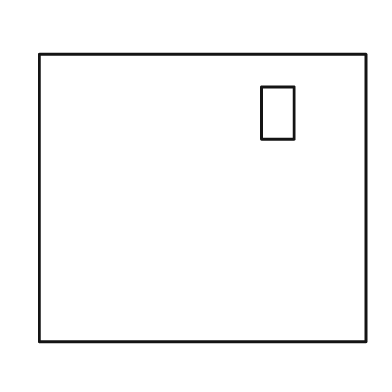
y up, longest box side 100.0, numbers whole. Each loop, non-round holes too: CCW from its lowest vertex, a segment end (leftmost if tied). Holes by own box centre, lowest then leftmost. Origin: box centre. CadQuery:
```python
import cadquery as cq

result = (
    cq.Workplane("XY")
    .moveTo(-50.0, -44.0)
    .lineTo(50.0, -44.0)
    .lineTo(50.0, 44.0)
    .lineTo(-50.0, 44.0)
    .close()
    .moveTo(18.0, 18.0)
    .lineTo(28.0, 18.0)
    .lineTo(28.0, 34.0)
    .lineTo(18.0, 34.0)
    .close()
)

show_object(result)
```